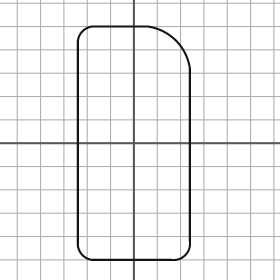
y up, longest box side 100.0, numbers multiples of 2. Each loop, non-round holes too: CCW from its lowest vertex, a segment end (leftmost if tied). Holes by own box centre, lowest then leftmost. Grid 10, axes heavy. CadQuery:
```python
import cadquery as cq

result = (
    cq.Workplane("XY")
    .moveTo(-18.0, -50.0)
    .lineTo(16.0, -50.0)
    .threePointArc((22.0, -48.0), (24.0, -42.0))
    .lineTo(24.0, 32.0)
    .threePointArc((18.0, 44.0), (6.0, 50.0))
    .lineTo(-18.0, 50.0)
    .threePointArc((-22.0, 48.0), (-24.0, 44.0))
    .lineTo(-24.0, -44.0)
    .threePointArc((-22.0, -48.0), (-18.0, -50.0))
    .close()
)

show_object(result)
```